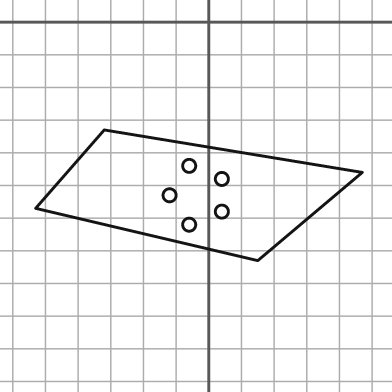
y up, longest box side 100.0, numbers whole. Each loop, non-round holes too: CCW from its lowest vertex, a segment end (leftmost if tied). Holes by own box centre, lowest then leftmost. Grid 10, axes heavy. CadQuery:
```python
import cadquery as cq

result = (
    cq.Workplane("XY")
    .moveTo(15.0, -73.0)
    .lineTo(47.0, -46.0)
    .lineTo(-32.0, -33.0)
    .lineTo(-53.0, -57.0)
    .close()
    .moveTo(-6.0, -62.0)
    .circle(2.0)
    .moveTo(4.0, -58.0)
    .circle(2.0)
    .moveTo(-12.0, -53.0)
    .circle(2.0)
    .moveTo(4.0, -48.0)
    .circle(2.0)
    .moveTo(-6.0, -44.0)
    .circle(2.0)
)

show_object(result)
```